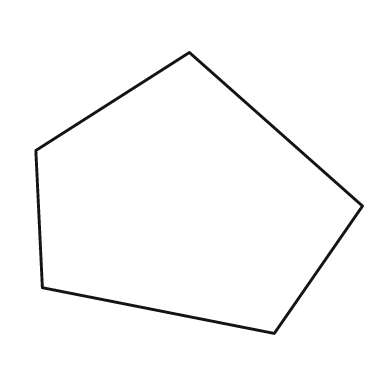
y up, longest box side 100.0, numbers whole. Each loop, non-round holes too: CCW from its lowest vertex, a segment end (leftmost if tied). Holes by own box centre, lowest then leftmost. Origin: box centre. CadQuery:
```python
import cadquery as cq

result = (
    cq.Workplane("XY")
    .moveTo(23.0, -43.0)
    .lineTo(50.0, -4.0)
    .lineTo(-3.0, 43.0)
    .lineTo(-50.0, 13.0)
    .lineTo(-48.0, -29.0)
    .close()
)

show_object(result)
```